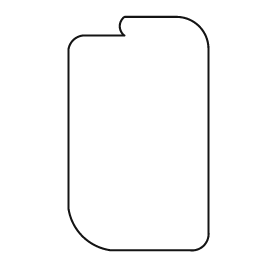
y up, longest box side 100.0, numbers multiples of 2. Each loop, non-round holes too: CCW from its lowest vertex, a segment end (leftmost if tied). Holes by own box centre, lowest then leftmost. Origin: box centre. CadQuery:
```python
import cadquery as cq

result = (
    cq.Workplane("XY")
    .moveTo(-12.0, -50.0)
    .lineTo(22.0, -50.0)
    .threePointArc((28.0, -48.0), (30.0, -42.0))
    .lineTo(30.0, 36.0)
    .threePointArc((26.0, 46.0), (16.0, 50.0))
    .lineTo(-6.0, 50.0)
    .threePointArc((-8.0, 46.0), (-6.0, 42.0))
    .lineTo(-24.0, 42.0)
    .threePointArc((-28.0, 40.0), (-30.0, 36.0))
    .lineTo(-30.0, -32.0)
    .threePointArc((-24.0, -44.0), (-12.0, -50.0))
    .close()
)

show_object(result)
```